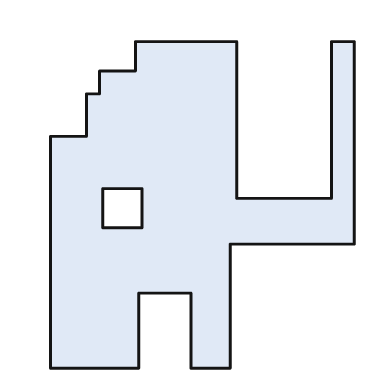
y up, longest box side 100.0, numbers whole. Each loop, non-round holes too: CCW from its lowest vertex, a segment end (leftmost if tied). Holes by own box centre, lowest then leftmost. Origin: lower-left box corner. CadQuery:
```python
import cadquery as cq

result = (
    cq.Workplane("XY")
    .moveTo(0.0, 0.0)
    .lineTo(27.0, 0.0)
    .lineTo(27.0, 23.0)
    .lineTo(43.0, 23.0)
    .lineTo(43.0, 0.0)
    .lineTo(55.0, 0.0)
    .lineTo(55.0, 38.0)
    .lineTo(93.0, 38.0)
    .lineTo(93.0, 100.0)
    .lineTo(86.0, 100.0)
    .lineTo(86.0, 52.0)
    .lineTo(57.0, 52.0)
    .lineTo(57.0, 100.0)
    .lineTo(26.0, 100.0)
    .lineTo(26.0, 91.0)
    .lineTo(15.0, 91.0)
    .lineTo(15.0, 84.0)
    .lineTo(11.0, 84.0)
    .lineTo(11.0, 71.0)
    .lineTo(0.0, 71.0)
    .close()
    .moveTo(16.0, 43.0)
    .lineTo(28.0, 43.0)
    .lineTo(28.0, 55.0)
    .lineTo(16.0, 55.0)
    .close()
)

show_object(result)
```